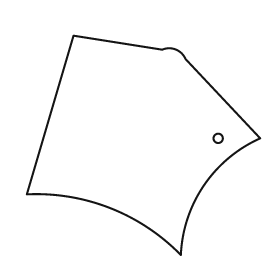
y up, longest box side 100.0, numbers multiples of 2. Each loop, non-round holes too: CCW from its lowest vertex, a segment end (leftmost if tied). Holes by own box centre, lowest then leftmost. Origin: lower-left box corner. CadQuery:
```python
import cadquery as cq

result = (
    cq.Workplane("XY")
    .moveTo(66.0, 0.0)
    .threePointArc((76.0, 30.0), (100.0, 50.0))
    .lineTo(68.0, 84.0)
    .threePointArc((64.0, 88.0), (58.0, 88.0))
    .lineTo(20.0, 94.0)
    .lineTo(0.0, 26.0)
    .threePointArc((36.0, 20.0), (66.0, 0.0))
    .close()
    .moveTo(82.0, 50.0)
    .circle(2.0)
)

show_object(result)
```